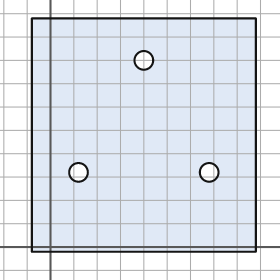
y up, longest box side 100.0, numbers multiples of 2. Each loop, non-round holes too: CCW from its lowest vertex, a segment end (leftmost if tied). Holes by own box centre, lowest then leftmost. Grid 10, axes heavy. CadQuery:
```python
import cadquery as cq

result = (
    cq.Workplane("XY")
    .moveTo(-8.0, -2.0)
    .lineTo(88.0, -2.0)
    .lineTo(88.0, 98.0)
    .lineTo(-8.0, 98.0)
    .close()
    .moveTo(12.0, 32.0)
    .circle(4.0)
    .moveTo(68.0, 32.0)
    .circle(4.0)
    .moveTo(40.0, 80.0)
    .circle(4.0)
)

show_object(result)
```